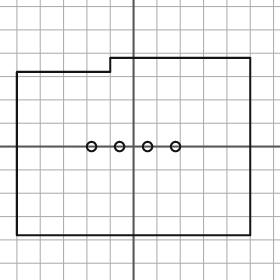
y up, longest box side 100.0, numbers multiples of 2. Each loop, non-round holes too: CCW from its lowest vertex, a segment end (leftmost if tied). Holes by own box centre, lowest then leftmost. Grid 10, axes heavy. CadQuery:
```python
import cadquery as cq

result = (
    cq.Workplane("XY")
    .moveTo(-50.0, -38.0)
    .lineTo(50.0, -38.0)
    .lineTo(50.0, 38.0)
    .lineTo(-10.0, 38.0)
    .lineTo(-10.0, 32.0)
    .lineTo(-50.0, 32.0)
    .close()
    .moveTo(-18.0, 0.0)
    .circle(2.0)
    .moveTo(-6.0, 0.0)
    .circle(2.0)
    .moveTo(6.0, 0.0)
    .circle(2.0)
    .moveTo(18.0, 0.0)
    .circle(2.0)
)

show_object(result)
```